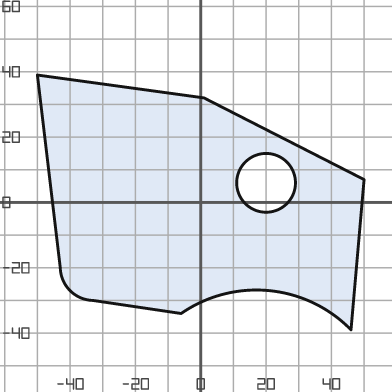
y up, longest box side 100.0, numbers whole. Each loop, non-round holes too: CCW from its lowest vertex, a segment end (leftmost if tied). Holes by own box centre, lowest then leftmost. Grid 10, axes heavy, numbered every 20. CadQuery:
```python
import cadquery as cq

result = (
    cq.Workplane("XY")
    .moveTo(46.0, -39.0)
    .lineTo(50.0, 7.0)
    .lineTo(1.0, 32.0)
    .lineTo(-50.0, 39.0)
    .lineTo(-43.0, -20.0)
    .threePointArc((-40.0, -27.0), (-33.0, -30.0))
    .lineTo(-6.0, -34.0)
    .threePointArc((21.0, -27.0), (46.0, -39.0))
    .close()
    .moveTo(20.0, 6.0)
    .circle(9.0)
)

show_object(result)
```